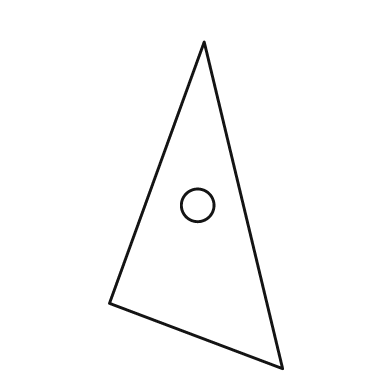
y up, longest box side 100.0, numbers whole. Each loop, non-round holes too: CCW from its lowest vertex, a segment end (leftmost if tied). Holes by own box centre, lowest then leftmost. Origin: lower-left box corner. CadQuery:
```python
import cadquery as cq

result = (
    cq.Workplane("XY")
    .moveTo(53.0, 0.0)
    .lineTo(29.0, 100.0)
    .lineTo(0.0, 20.0)
    .close()
    .moveTo(27.0, 50.0)
    .circle(5.0)
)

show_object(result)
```